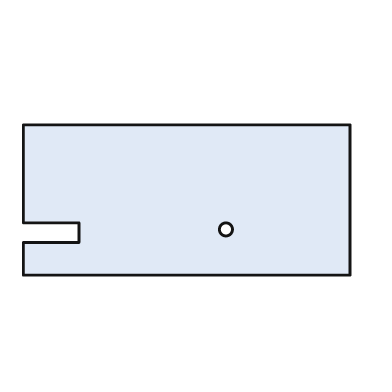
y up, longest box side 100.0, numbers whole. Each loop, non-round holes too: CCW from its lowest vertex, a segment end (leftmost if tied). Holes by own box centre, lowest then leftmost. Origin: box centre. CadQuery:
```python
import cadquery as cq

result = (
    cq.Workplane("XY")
    .moveTo(-50.0, -23.0)
    .lineTo(50.0, -23.0)
    .lineTo(50.0, 23.0)
    .lineTo(-50.0, 23.0)
    .lineTo(-50.0, -7.0)
    .lineTo(-33.0, -7.0)
    .lineTo(-33.0, -13.0)
    .lineTo(-50.0, -13.0)
    .close()
    .moveTo(12.0, -9.0)
    .circle(2.0)
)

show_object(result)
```